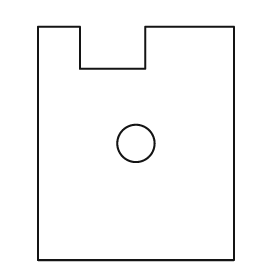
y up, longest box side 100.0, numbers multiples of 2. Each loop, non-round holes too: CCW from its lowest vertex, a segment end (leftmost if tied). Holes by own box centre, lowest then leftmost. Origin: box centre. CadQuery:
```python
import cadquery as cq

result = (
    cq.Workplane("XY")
    .moveTo(-42.0, -50.0)
    .lineTo(42.0, -50.0)
    .lineTo(42.0, 50.0)
    .lineTo(4.0, 50.0)
    .lineTo(4.0, 32.0)
    .lineTo(-24.0, 32.0)
    .lineTo(-24.0, 50.0)
    .lineTo(-42.0, 50.0)
    .close()
    .moveTo(0.0, 0.0)
    .circle(8.0)
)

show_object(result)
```